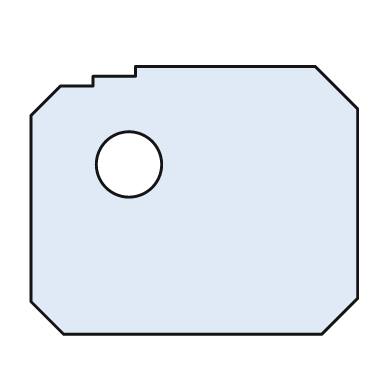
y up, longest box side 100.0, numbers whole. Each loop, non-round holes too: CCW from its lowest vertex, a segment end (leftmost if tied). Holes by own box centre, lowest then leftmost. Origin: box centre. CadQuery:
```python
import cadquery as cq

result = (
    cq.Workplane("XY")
    .moveTo(-40.0, -41.0)
    .lineTo(39.0, -41.0)
    .lineTo(50.0, -30.0)
    .lineTo(50.0, 28.0)
    .lineTo(37.0, 41.0)
    .lineTo(-18.0, 41.0)
    .lineTo(-18.0, 38.0)
    .lineTo(-31.0, 38.0)
    .lineTo(-31.0, 35.0)
    .lineTo(-41.0, 35.0)
    .lineTo(-50.0, 26.0)
    .lineTo(-50.0, -31.0)
    .close()
    .moveTo(-20.0, 11.0)
    .circle(10.0)
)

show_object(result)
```